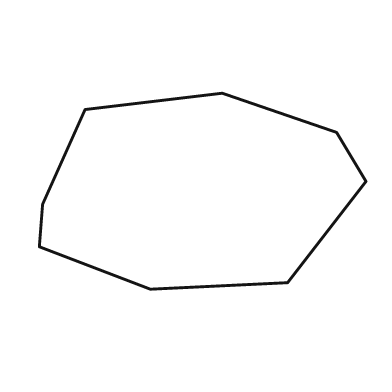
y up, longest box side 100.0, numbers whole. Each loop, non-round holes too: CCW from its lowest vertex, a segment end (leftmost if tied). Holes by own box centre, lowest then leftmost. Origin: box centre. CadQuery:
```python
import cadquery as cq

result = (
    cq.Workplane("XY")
    .moveTo(-16.0, -30.0)
    .lineTo(26.0, -28.0)
    .lineTo(50.0, 3.0)
    .lineTo(41.0, 18.0)
    .lineTo(6.0, 30.0)
    .lineTo(-36.0, 25.0)
    .lineTo(-49.0, -4.0)
    .lineTo(-50.0, -17.0)
    .close()
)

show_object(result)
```